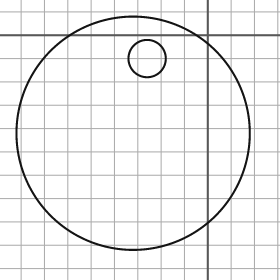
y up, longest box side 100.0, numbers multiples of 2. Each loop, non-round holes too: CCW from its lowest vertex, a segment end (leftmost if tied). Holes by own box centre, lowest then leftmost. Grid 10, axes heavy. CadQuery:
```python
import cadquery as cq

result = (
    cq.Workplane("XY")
    .moveTo(-32.0, -42.0)
    .circle(50.0)
    .moveTo(-26.0, -10.0)
    .circle(8.0)
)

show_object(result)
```